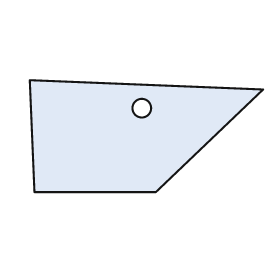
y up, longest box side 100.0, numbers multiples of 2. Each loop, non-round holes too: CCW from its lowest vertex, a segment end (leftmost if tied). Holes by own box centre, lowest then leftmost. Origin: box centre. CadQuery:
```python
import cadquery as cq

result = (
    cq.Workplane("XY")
    .moveTo(-48.0, -24.0)
    .lineTo(4.0, -24.0)
    .lineTo(50.0, 20.0)
    .lineTo(-50.0, 24.0)
    .close()
    .moveTo(-2.0, 12.0)
    .circle(4.0)
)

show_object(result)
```